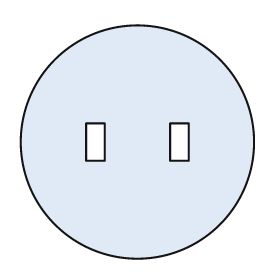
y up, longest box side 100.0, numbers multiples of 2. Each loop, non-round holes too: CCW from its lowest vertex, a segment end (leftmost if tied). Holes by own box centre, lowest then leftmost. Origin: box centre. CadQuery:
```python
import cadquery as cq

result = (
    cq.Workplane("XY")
    .moveTo(0.0, 0.0)
    .circle(50.0)
    .moveTo(-22.0, -8.0)
    .lineTo(-14.0, -8.0)
    .lineTo(-14.0, 8.0)
    .lineTo(-22.0, 8.0)
    .close()
    .moveTo(14.0, -8.0)
    .lineTo(22.0, -8.0)
    .lineTo(22.0, 8.0)
    .lineTo(14.0, 8.0)
    .close()
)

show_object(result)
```